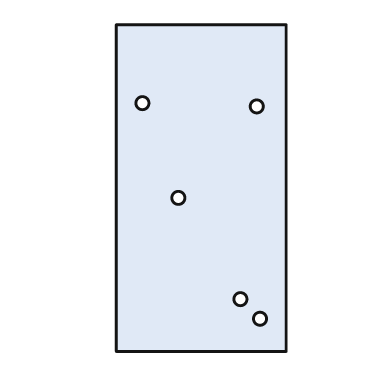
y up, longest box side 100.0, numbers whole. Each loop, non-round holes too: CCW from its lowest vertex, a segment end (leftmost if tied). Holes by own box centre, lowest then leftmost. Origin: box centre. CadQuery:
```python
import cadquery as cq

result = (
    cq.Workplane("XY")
    .moveTo(-26.0, -50.0)
    .lineTo(26.0, -50.0)
    .lineTo(26.0, 50.0)
    .lineTo(-26.0, 50.0)
    .close()
    .moveTo(18.0, -40.0)
    .circle(2.0)
    .moveTo(12.0, -34.0)
    .circle(2.0)
    .moveTo(-7.0, -3.0)
    .circle(2.0)
    .moveTo(17.0, 25.0)
    .circle(2.0)
    .moveTo(-18.0, 26.0)
    .circle(2.0)
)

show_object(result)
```